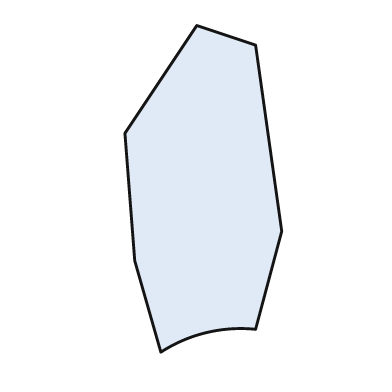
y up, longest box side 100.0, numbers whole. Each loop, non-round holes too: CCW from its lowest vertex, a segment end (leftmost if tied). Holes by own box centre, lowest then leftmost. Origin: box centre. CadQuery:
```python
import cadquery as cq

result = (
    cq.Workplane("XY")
    .moveTo(-13.0, -50.0)
    .threePointArc((1.0, -44.0), (16.0, -43.0))
    .lineTo(24.0, -13.0)
    .lineTo(16.0, 44.0)
    .lineTo(-2.0, 50.0)
    .lineTo(-24.0, 17.0)
    .lineTo(-21.0, -22.0)
    .close()
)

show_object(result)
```